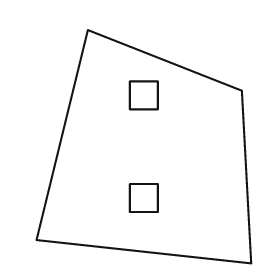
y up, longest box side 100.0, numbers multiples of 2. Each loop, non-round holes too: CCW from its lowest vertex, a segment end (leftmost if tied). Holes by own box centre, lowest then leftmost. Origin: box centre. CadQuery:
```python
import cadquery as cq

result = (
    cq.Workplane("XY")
    .moveTo(46.0, -50.0)
    .lineTo(42.0, 24.0)
    .lineTo(-24.0, 50.0)
    .lineTo(-46.0, -40.0)
    .close()
    .moveTo(-6.0, -28.0)
    .lineTo(6.0, -28.0)
    .lineTo(6.0, -16.0)
    .lineTo(-6.0, -16.0)
    .close()
    .moveTo(-6.0, 16.0)
    .lineTo(6.0, 16.0)
    .lineTo(6.0, 28.0)
    .lineTo(-6.0, 28.0)
    .close()
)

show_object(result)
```